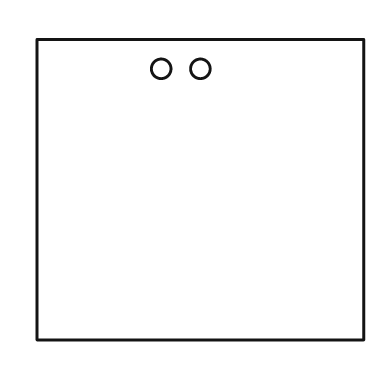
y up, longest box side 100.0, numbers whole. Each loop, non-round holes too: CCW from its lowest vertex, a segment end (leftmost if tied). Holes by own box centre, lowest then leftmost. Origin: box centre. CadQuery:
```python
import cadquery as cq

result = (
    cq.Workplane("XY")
    .moveTo(-50.0, -46.0)
    .lineTo(50.0, -46.0)
    .lineTo(50.0, 46.0)
    .lineTo(-50.0, 46.0)
    .close()
    .moveTo(-12.0, 37.0)
    .circle(3.0)
    .moveTo(0.0, 37.0)
    .circle(3.0)
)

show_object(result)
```